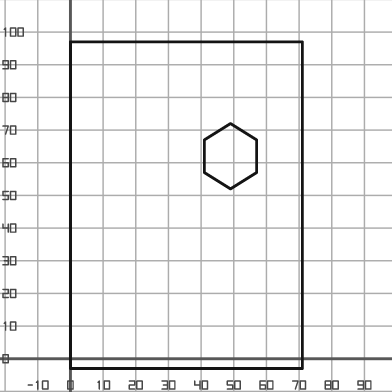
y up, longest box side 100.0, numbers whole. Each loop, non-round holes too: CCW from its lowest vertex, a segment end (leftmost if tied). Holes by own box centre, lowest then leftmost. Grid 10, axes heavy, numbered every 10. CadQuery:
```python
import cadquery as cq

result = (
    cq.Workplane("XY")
    .moveTo(0.0, -3.0)
    .lineTo(71.0, -3.0)
    .lineTo(71.0, 97.0)
    .lineTo(0.0, 97.0)
    .close()
    .moveTo(49.0, 52.0)
    .lineTo(57.0, 57.0)
    .lineTo(57.0, 67.0)
    .lineTo(49.0, 72.0)
    .lineTo(41.0, 67.0)
    .lineTo(41.0, 57.0)
    .close()
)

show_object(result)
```